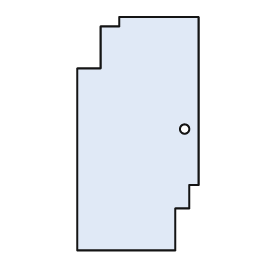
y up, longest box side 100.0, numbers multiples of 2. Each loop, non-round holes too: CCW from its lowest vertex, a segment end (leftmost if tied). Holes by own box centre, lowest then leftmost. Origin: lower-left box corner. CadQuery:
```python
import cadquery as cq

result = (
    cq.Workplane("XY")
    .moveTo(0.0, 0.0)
    .lineTo(42.0, 0.0)
    .lineTo(42.0, 18.0)
    .lineTo(48.0, 18.0)
    .lineTo(48.0, 28.0)
    .lineTo(52.0, 28.0)
    .lineTo(52.0, 100.0)
    .lineTo(18.0, 100.0)
    .lineTo(18.0, 96.0)
    .lineTo(10.0, 96.0)
    .lineTo(10.0, 78.0)
    .lineTo(0.0, 78.0)
    .close()
    .moveTo(46.0, 52.0)
    .circle(2.0)
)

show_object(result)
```